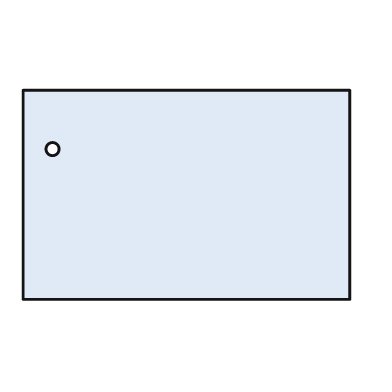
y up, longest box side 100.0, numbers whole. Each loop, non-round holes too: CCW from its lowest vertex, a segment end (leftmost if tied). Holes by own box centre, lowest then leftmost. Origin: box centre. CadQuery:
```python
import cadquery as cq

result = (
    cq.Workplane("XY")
    .moveTo(-50.0, -32.0)
    .lineTo(50.0, -32.0)
    .lineTo(50.0, 32.0)
    .lineTo(-50.0, 32.0)
    .close()
    .moveTo(-41.0, 14.0)
    .circle(2.0)
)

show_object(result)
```